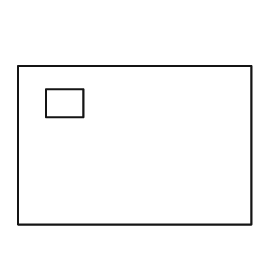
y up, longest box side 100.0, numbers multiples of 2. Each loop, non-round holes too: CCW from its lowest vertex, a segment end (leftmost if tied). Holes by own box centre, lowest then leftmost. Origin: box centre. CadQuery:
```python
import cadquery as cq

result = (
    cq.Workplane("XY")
    .moveTo(-50.0, -34.0)
    .lineTo(50.0, -34.0)
    .lineTo(50.0, 34.0)
    .lineTo(-50.0, 34.0)
    .close()
    .moveTo(-38.0, 12.0)
    .lineTo(-22.0, 12.0)
    .lineTo(-22.0, 24.0)
    .lineTo(-38.0, 24.0)
    .close()
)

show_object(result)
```